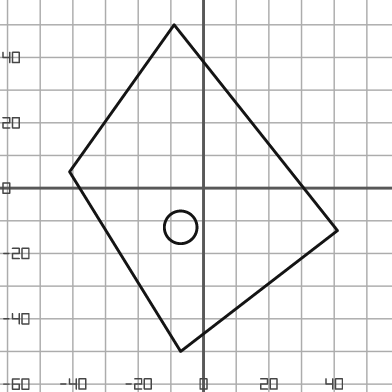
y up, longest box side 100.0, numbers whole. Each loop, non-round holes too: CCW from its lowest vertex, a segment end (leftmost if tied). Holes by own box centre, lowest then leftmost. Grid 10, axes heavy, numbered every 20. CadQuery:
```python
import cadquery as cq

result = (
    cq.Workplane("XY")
    .moveTo(-7.0, -50.0)
    .lineTo(41.0, -13.0)
    .lineTo(-9.0, 50.0)
    .lineTo(-41.0, 5.0)
    .close()
    .moveTo(-7.0, -12.0)
    .circle(5.0)
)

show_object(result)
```